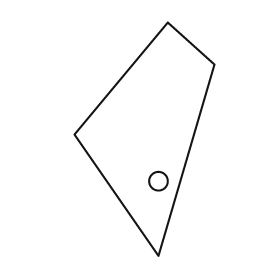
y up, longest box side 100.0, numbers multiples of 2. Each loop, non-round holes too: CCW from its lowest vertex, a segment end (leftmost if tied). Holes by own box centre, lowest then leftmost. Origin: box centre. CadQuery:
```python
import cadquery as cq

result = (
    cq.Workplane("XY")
    .moveTo(6.0, -50.0)
    .lineTo(30.0, 32.0)
    .lineTo(10.0, 50.0)
    .lineTo(-30.0, 2.0)
    .close()
    .moveTo(6.0, -18.0)
    .circle(4.0)
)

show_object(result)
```